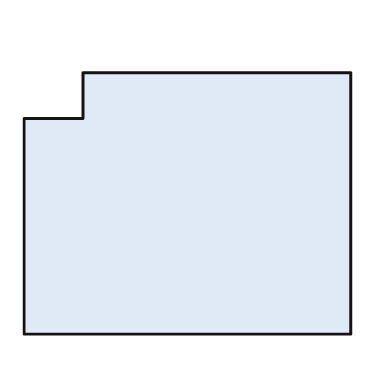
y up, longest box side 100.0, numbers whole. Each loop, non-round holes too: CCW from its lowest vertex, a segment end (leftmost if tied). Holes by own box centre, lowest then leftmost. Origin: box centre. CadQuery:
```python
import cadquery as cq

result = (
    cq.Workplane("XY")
    .moveTo(-50.0, -40.0)
    .lineTo(50.0, -40.0)
    .lineTo(50.0, 40.0)
    .lineTo(-32.0, 40.0)
    .lineTo(-32.0, 26.0)
    .lineTo(-50.0, 26.0)
    .close()
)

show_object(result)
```